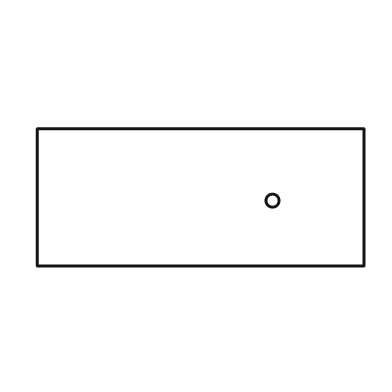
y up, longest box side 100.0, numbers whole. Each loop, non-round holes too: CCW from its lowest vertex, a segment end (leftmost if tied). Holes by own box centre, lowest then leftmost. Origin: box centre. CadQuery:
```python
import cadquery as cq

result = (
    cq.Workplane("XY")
    .moveTo(-50.0, -21.0)
    .lineTo(50.0, -21.0)
    .lineTo(50.0, 21.0)
    .lineTo(-50.0, 21.0)
    .close()
    .moveTo(22.0, -1.0)
    .circle(2.0)
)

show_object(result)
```